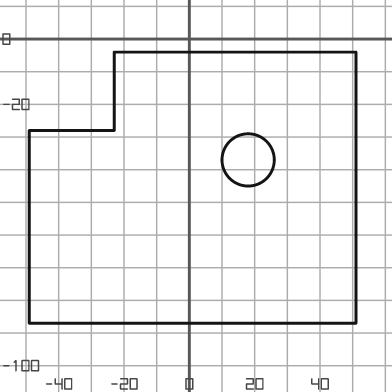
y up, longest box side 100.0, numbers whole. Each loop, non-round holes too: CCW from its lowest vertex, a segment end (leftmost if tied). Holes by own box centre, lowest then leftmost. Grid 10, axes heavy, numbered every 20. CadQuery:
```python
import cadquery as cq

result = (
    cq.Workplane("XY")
    .moveTo(-49.0, -87.0)
    .lineTo(51.0, -87.0)
    .lineTo(51.0, -4.0)
    .lineTo(-23.0, -4.0)
    .lineTo(-23.0, -28.0)
    .lineTo(-49.0, -28.0)
    .close()
    .moveTo(18.0, -37.0)
    .circle(8.0)
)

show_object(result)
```